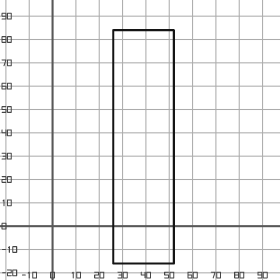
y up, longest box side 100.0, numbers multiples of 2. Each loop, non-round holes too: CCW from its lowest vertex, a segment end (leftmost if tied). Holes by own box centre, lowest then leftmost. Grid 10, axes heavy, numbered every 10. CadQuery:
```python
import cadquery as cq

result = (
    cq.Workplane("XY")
    .moveTo(26.0, -16.0)
    .lineTo(52.0, -16.0)
    .lineTo(52.0, 84.0)
    .lineTo(26.0, 84.0)
    .close()
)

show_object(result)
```